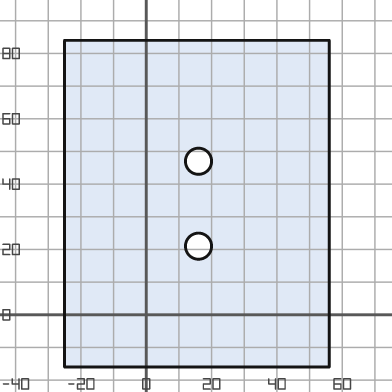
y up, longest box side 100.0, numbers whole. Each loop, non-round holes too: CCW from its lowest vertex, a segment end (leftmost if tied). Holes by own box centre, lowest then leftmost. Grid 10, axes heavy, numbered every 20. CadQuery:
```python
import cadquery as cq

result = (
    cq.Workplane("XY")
    .moveTo(-25.0, -16.0)
    .lineTo(56.0, -16.0)
    .lineTo(56.0, 84.0)
    .lineTo(-25.0, 84.0)
    .close()
    .moveTo(16.0, 21.0)
    .circle(4.0)
    .moveTo(16.0, 47.0)
    .circle(4.0)
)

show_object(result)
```